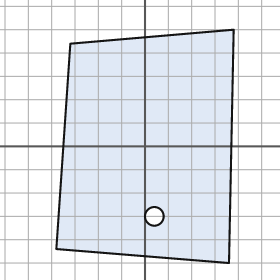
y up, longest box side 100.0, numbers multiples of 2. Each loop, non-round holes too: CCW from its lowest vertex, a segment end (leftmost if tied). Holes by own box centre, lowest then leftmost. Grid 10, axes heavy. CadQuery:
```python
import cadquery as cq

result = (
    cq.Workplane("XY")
    .moveTo(36.0, -50.0)
    .lineTo(38.0, 50.0)
    .lineTo(-32.0, 44.0)
    .lineTo(-38.0, -44.0)
    .close()
    .moveTo(4.0, -30.0)
    .circle(4.0)
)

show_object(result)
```